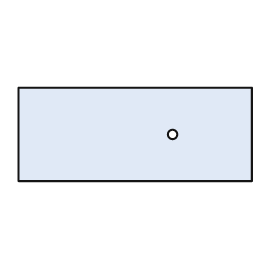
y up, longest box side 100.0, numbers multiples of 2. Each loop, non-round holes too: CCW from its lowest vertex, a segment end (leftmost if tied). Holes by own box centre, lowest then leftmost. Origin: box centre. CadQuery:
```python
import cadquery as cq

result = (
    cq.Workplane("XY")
    .moveTo(-50.0, -20.0)
    .lineTo(50.0, -20.0)
    .lineTo(50.0, 20.0)
    .lineTo(-50.0, 20.0)
    .close()
    .moveTo(16.0, 0.0)
    .circle(2.0)
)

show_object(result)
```